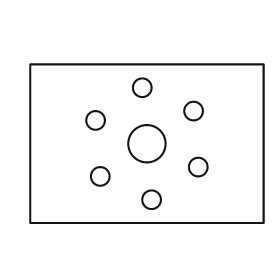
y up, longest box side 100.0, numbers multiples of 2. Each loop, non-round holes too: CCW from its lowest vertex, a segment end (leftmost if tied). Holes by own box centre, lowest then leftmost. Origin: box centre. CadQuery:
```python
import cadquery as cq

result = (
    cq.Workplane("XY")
    .moveTo(-50.0, -34.0)
    .lineTo(50.0, -34.0)
    .lineTo(50.0, 34.0)
    .lineTo(-50.0, 34.0)
    .close()
    .moveTo(2.0, -24.0)
    .circle(4.0)
    .moveTo(-20.0, -14.0)
    .circle(4.0)
    .moveTo(22.0, -10.0)
    .circle(4.0)
    .moveTo(0.0, 0.0)
    .circle(8.0)
    .moveTo(-22.0, 10.0)
    .circle(4.0)
    .moveTo(20.0, 14.0)
    .circle(4.0)
    .moveTo(-2.0, 24.0)
    .circle(4.0)
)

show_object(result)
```